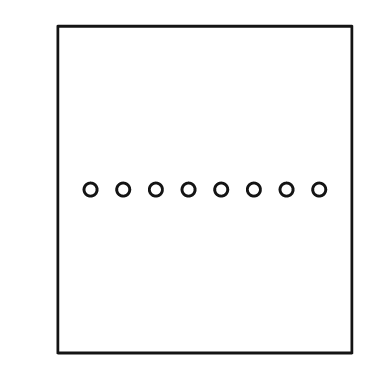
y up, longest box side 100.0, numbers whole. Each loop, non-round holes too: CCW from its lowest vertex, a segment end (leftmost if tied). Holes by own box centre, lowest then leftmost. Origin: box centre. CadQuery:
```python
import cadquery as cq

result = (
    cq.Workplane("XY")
    .moveTo(-45.0, -50.0)
    .lineTo(45.0, -50.0)
    .lineTo(45.0, 50.0)
    .lineTo(-45.0, 50.0)
    .close()
    .moveTo(-35.0, 0.0)
    .circle(2.0)
    .moveTo(-25.0, 0.0)
    .circle(2.0)
    .moveTo(-15.0, 0.0)
    .circle(2.0)
    .moveTo(-5.0, 0.0)
    .circle(2.0)
    .moveTo(5.0, 0.0)
    .circle(2.0)
    .moveTo(15.0, 0.0)
    .circle(2.0)
    .moveTo(25.0, 0.0)
    .circle(2.0)
    .moveTo(35.0, 0.0)
    .circle(2.0)
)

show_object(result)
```